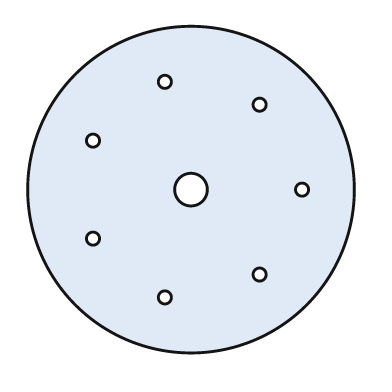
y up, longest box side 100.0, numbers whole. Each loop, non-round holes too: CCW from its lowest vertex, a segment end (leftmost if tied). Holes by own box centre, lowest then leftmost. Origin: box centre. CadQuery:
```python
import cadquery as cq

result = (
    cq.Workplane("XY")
    .moveTo(0.0, 0.0)
    .circle(50.0)
    .moveTo(-8.0, -33.0)
    .circle(2.0)
    .moveTo(21.0, -26.0)
    .circle(2.0)
    .moveTo(-30.0, -15.0)
    .circle(2.0)
    .moveTo(0.0, 0.0)
    .circle(5.0)
    .moveTo(34.0, 0.0)
    .circle(2.0)
    .moveTo(-30.0, 15.0)
    .circle(2.0)
    .moveTo(21.0, 26.0)
    .circle(2.0)
    .moveTo(-8.0, 33.0)
    .circle(2.0)
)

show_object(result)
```